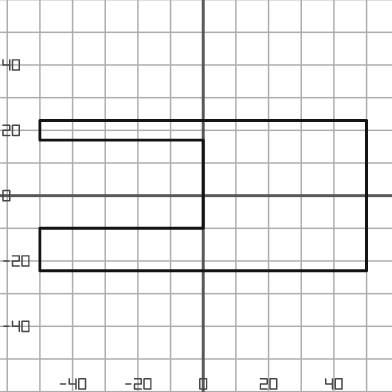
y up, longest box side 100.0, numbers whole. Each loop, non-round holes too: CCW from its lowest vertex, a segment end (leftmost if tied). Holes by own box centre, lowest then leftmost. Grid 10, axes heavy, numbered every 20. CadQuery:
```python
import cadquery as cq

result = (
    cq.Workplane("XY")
    .moveTo(-50.0, -23.0)
    .lineTo(50.0, -23.0)
    .lineTo(50.0, 23.0)
    .lineTo(-50.0, 23.0)
    .lineTo(-50.0, 17.0)
    .lineTo(0.0, 17.0)
    .lineTo(0.0, -10.0)
    .lineTo(-50.0, -10.0)
    .close()
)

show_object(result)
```